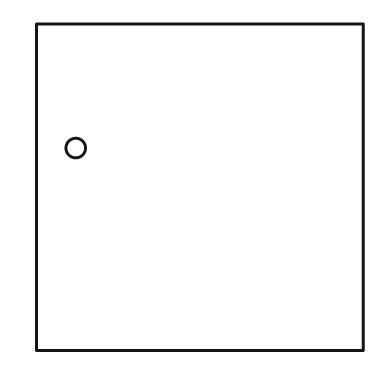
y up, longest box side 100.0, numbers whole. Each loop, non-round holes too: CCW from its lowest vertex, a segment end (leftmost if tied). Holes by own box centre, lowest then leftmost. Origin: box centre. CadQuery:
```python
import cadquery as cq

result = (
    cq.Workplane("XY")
    .moveTo(-50.0, -50.0)
    .lineTo(50.0, -50.0)
    .lineTo(50.0, 50.0)
    .lineTo(-50.0, 50.0)
    .close()
    .moveTo(-38.0, 12.0)
    .circle(3.0)
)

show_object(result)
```